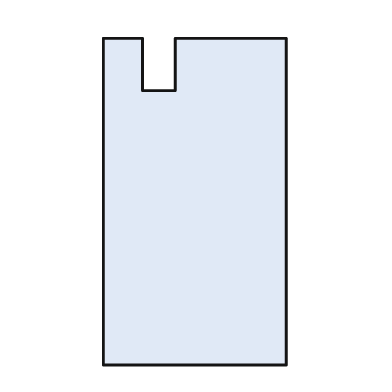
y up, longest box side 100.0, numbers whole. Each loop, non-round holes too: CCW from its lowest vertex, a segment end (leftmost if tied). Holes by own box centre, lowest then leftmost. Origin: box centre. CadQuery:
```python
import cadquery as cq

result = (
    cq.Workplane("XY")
    .moveTo(-28.0, -50.0)
    .lineTo(28.0, -50.0)
    .lineTo(28.0, 50.0)
    .lineTo(-6.0, 50.0)
    .lineTo(-6.0, 34.0)
    .lineTo(-16.0, 34.0)
    .lineTo(-16.0, 50.0)
    .lineTo(-28.0, 50.0)
    .close()
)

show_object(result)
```